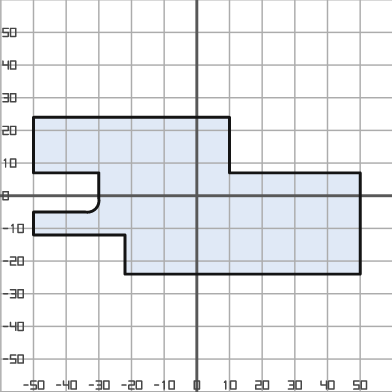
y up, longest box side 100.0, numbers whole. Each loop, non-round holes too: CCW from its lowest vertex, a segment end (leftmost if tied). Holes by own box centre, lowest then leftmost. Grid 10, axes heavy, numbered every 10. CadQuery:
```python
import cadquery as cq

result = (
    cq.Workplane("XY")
    .moveTo(-22.0, -24.0)
    .lineTo(50.0, -24.0)
    .lineTo(50.0, 7.0)
    .lineTo(10.0, 7.0)
    .lineTo(10.0, 24.0)
    .lineTo(-50.0, 24.0)
    .lineTo(-50.0, 7.0)
    .lineTo(-30.0, 7.0)
    .lineTo(-30.0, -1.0)
    .threePointArc((-31.0, -4.0), (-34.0, -5.0))
    .lineTo(-50.0, -5.0)
    .lineTo(-50.0, -12.0)
    .lineTo(-22.0, -12.0)
    .close()
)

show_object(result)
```